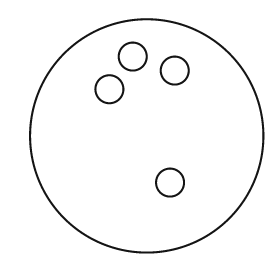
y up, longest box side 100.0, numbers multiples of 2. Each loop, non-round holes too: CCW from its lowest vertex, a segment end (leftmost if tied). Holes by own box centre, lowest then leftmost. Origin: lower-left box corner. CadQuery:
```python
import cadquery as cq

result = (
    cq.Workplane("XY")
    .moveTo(50.0, 50.0)
    .circle(50.0)
    .moveTo(60.0, 30.0)
    .circle(6.0)
    .moveTo(34.0, 70.0)
    .circle(6.0)
    .moveTo(62.0, 78.0)
    .circle(6.0)
    .moveTo(44.0, 84.0)
    .circle(6.0)
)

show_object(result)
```